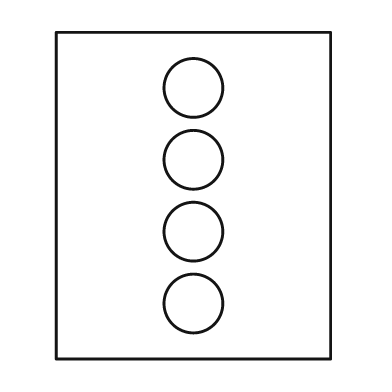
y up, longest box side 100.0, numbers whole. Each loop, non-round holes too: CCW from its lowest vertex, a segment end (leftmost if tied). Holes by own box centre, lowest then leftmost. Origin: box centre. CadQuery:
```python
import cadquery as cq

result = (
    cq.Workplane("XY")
    .moveTo(-42.0, -50.0)
    .lineTo(42.0, -50.0)
    .lineTo(42.0, 50.0)
    .lineTo(-42.0, 50.0)
    .close()
    .moveTo(0.0, -33.0)
    .circle(9.0)
    .moveTo(0.0, -11.0)
    .circle(9.0)
    .moveTo(0.0, 11.0)
    .circle(9.0)
    .moveTo(0.0, 33.0)
    .circle(9.0)
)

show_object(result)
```